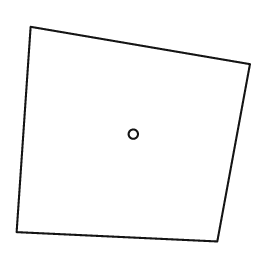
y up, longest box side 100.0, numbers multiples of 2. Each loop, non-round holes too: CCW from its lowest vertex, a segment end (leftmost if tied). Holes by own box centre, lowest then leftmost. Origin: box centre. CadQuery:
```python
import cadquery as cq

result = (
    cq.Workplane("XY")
    .moveTo(36.0, -46.0)
    .lineTo(50.0, 30.0)
    .lineTo(-44.0, 46.0)
    .lineTo(-50.0, -42.0)
    .close()
    .moveTo(0.0, 0.0)
    .circle(2.0)
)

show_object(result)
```